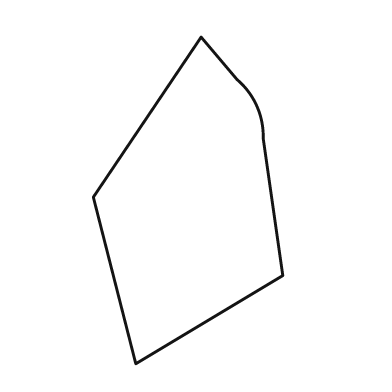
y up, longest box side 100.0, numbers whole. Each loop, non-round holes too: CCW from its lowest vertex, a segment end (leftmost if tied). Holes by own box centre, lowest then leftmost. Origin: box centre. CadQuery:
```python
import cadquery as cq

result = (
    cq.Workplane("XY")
    .moveTo(-16.0, -50.0)
    .lineTo(29.0, -23.0)
    .lineTo(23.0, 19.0)
    .threePointArc((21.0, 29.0), (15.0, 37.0))
    .lineTo(4.0, 50.0)
    .lineTo(-29.0, 1.0)
    .close()
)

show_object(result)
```